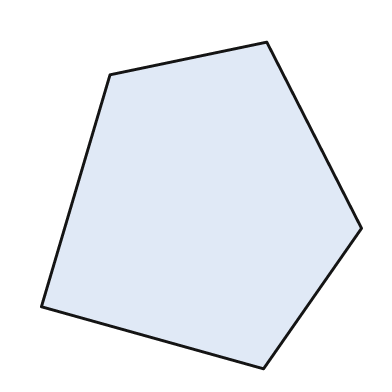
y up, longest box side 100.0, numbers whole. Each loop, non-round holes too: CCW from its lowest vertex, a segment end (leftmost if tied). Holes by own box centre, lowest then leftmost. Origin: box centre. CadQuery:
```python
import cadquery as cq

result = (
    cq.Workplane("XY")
    .moveTo(19.0, -50.0)
    .lineTo(49.0, -7.0)
    .lineTo(20.0, 50.0)
    .lineTo(-28.0, 40.0)
    .lineTo(-49.0, -31.0)
    .close()
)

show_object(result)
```